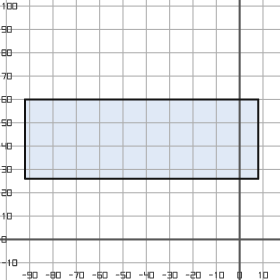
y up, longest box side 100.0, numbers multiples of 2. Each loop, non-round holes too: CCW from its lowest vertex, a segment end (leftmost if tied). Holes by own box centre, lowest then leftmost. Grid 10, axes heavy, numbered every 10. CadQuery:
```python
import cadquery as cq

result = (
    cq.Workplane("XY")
    .moveTo(-92.0, 26.0)
    .lineTo(8.0, 26.0)
    .lineTo(8.0, 60.0)
    .lineTo(-92.0, 60.0)
    .close()
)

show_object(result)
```